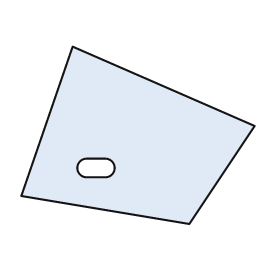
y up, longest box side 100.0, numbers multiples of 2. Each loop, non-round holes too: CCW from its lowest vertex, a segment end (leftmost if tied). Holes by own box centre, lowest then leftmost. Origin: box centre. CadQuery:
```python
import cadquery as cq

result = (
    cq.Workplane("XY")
    .moveTo(22.0, -38.0)
    .lineTo(50.0, 4.0)
    .lineTo(-28.0, 38.0)
    .lineTo(-50.0, -26.0)
    .close()
    .moveTo(-22.0, -18.0)
    .lineTo(-14.0, -18.0)
    .threePointArc((-10.0, -14.0), (-14.0, -10.0))
    .lineTo(-22.0, -10.0)
    .threePointArc((-26.0, -14.0), (-22.0, -18.0))
    .close()
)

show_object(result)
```